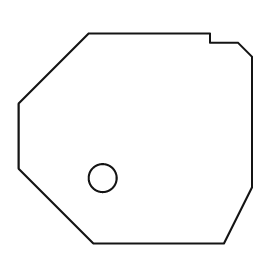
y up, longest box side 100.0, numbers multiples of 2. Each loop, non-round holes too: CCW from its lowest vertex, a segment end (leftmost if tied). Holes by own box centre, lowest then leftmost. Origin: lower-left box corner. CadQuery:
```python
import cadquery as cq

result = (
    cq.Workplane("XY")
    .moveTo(32.0, 0.0)
    .lineTo(88.0, 0.0)
    .lineTo(100.0, 24.0)
    .lineTo(100.0, 80.0)
    .lineTo(94.0, 86.0)
    .lineTo(82.0, 86.0)
    .lineTo(82.0, 90.0)
    .lineTo(30.0, 90.0)
    .lineTo(0.0, 60.0)
    .lineTo(0.0, 32.0)
    .close()
    .moveTo(36.0, 28.0)
    .circle(6.0)
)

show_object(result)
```